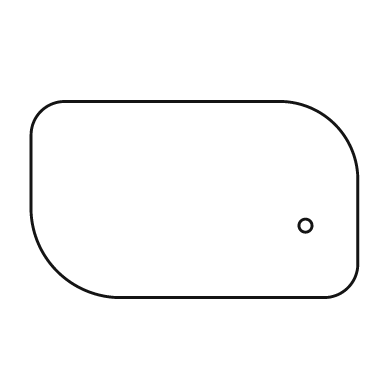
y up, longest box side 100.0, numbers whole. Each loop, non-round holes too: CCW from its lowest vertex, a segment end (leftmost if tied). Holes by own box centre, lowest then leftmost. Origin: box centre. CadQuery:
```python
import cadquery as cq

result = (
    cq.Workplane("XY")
    .moveTo(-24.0, -30.0)
    .lineTo(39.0, -30.0)
    .threePointArc((47.0, -27.0), (50.0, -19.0))
    .lineTo(50.0, 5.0)
    .threePointArc((43.0, 23.0), (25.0, 30.0))
    .lineTo(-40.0, 30.0)
    .threePointArc((-47.0, 27.0), (-50.0, 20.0))
    .lineTo(-50.0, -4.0)
    .threePointArc((-42.0, -22.0), (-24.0, -30.0))
    .close()
    .moveTo(34.0, -8.0)
    .circle(2.0)
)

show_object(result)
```